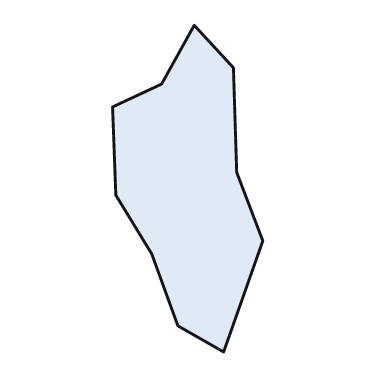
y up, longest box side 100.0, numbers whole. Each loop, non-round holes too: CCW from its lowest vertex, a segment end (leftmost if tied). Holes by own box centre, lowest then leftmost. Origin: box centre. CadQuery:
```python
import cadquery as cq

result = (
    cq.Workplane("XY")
    .moveTo(11.0, -50.0)
    .lineTo(23.0, -16.0)
    .lineTo(15.0, 5.0)
    .lineTo(14.0, 37.0)
    .lineTo(2.0, 50.0)
    .lineTo(-8.0, 32.0)
    .lineTo(-23.0, 25.0)
    .lineTo(-22.0, -2.0)
    .lineTo(-11.0, -20.0)
    .lineTo(-3.0, -42.0)
    .close()
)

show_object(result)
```